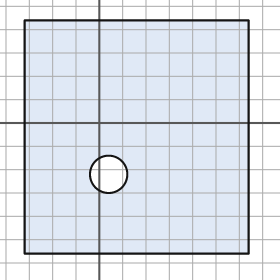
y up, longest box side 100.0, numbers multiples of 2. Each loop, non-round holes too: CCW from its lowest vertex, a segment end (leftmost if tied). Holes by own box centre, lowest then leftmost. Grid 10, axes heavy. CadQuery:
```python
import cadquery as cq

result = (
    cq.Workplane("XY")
    .moveTo(-32.0, -56.0)
    .lineTo(64.0, -56.0)
    .lineTo(64.0, 44.0)
    .lineTo(-32.0, 44.0)
    .close()
    .moveTo(4.0, -22.0)
    .circle(8.0)
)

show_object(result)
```